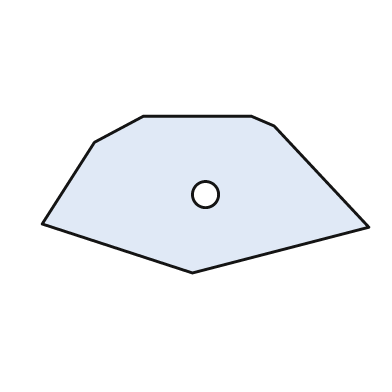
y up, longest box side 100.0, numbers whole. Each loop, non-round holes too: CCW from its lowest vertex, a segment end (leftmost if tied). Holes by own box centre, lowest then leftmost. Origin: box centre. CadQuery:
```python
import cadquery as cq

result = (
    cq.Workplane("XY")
    .moveTo(-4.0, -24.0)
    .lineTo(50.0, -10.0)
    .lineTo(21.0, 21.0)
    .lineTo(14.0, 24.0)
    .lineTo(-19.0, 24.0)
    .lineTo(-34.0, 16.0)
    .lineTo(-50.0, -9.0)
    .close()
    .moveTo(0.0, 0.0)
    .circle(4.0)
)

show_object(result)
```